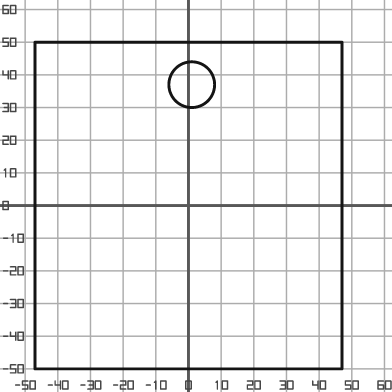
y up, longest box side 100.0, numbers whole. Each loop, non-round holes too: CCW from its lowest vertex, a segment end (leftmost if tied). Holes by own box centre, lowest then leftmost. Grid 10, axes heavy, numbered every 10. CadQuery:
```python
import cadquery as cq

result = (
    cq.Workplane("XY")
    .moveTo(-47.0, -50.0)
    .lineTo(47.0, -50.0)
    .lineTo(47.0, 50.0)
    .lineTo(-47.0, 50.0)
    .close()
    .moveTo(1.0, 37.0)
    .circle(7.0)
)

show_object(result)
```